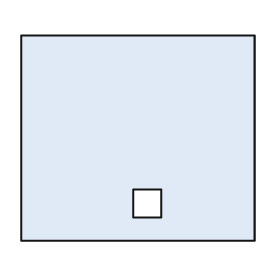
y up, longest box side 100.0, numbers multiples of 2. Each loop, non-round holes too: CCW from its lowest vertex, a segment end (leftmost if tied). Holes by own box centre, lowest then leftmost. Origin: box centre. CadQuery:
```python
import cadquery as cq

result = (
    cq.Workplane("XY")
    .moveTo(-50.0, -44.0)
    .lineTo(50.0, -44.0)
    .lineTo(50.0, 44.0)
    .lineTo(-50.0, 44.0)
    .close()
    .moveTo(-2.0, -34.0)
    .lineTo(10.0, -34.0)
    .lineTo(10.0, -22.0)
    .lineTo(-2.0, -22.0)
    .close()
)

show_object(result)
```